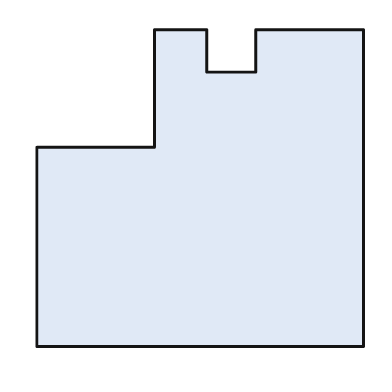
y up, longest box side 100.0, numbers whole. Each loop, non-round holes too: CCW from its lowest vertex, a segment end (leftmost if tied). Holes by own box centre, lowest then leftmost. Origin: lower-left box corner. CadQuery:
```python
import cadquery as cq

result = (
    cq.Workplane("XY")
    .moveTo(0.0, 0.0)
    .lineTo(100.0, 0.0)
    .lineTo(100.0, 97.0)
    .lineTo(67.0, 97.0)
    .lineTo(67.0, 84.0)
    .lineTo(52.0, 84.0)
    .lineTo(52.0, 97.0)
    .lineTo(36.0, 97.0)
    .lineTo(36.0, 61.0)
    .lineTo(0.0, 61.0)
    .close()
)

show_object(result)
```